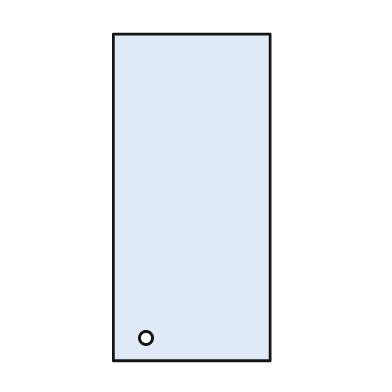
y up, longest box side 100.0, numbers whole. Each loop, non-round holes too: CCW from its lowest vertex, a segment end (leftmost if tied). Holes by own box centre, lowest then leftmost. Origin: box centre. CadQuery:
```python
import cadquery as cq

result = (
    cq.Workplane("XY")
    .moveTo(-24.0, -50.0)
    .lineTo(24.0, -50.0)
    .lineTo(24.0, 50.0)
    .lineTo(-24.0, 50.0)
    .close()
    .moveTo(-14.0, -43.0)
    .circle(2.0)
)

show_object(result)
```